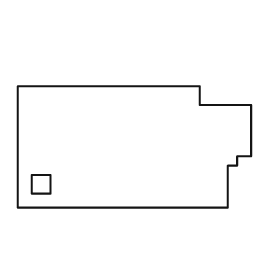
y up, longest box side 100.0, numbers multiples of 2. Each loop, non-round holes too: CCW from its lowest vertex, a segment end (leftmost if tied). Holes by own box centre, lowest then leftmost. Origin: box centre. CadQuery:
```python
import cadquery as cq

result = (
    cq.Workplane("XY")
    .moveTo(-50.0, -26.0)
    .lineTo(40.0, -26.0)
    .lineTo(40.0, -8.0)
    .lineTo(44.0, -8.0)
    .lineTo(44.0, -4.0)
    .lineTo(50.0, -4.0)
    .lineTo(50.0, 18.0)
    .lineTo(28.0, 18.0)
    .lineTo(28.0, 26.0)
    .lineTo(-50.0, 26.0)
    .close()
    .moveTo(-44.0, -20.0)
    .lineTo(-36.0, -20.0)
    .lineTo(-36.0, -12.0)
    .lineTo(-44.0, -12.0)
    .close()
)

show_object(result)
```